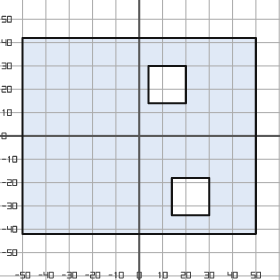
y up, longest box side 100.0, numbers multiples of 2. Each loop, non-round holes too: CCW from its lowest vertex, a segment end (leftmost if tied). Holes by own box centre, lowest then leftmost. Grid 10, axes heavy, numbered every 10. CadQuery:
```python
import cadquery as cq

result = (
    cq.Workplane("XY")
    .moveTo(-50.0, -42.0)
    .lineTo(50.0, -42.0)
    .lineTo(50.0, 42.0)
    .lineTo(-50.0, 42.0)
    .close()
    .moveTo(14.0, -34.0)
    .lineTo(30.0, -34.0)
    .lineTo(30.0, -18.0)
    .lineTo(14.0, -18.0)
    .close()
    .moveTo(4.0, 14.0)
    .lineTo(20.0, 14.0)
    .lineTo(20.0, 30.0)
    .lineTo(4.0, 30.0)
    .close()
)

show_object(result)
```